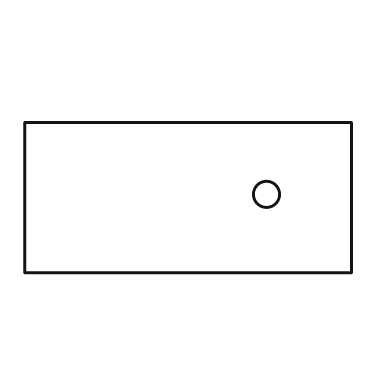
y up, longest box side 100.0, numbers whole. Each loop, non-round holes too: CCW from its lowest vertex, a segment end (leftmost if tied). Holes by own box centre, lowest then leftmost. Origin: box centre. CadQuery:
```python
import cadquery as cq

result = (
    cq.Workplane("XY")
    .moveTo(-50.0, -23.0)
    .lineTo(50.0, -23.0)
    .lineTo(50.0, 23.0)
    .lineTo(-50.0, 23.0)
    .close()
    .moveTo(24.0, 1.0)
    .circle(4.0)
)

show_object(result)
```